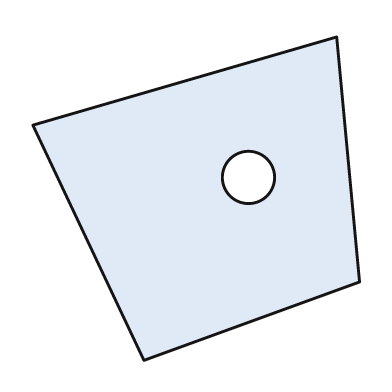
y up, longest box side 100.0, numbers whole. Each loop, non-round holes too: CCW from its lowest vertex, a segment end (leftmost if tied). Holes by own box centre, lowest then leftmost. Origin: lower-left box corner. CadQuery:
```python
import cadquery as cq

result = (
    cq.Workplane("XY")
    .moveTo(34.0, 0.0)
    .lineTo(100.0, 24.0)
    .lineTo(93.0, 99.0)
    .lineTo(0.0, 72.0)
    .close()
    .moveTo(66.0, 56.0)
    .circle(8.0)
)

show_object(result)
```